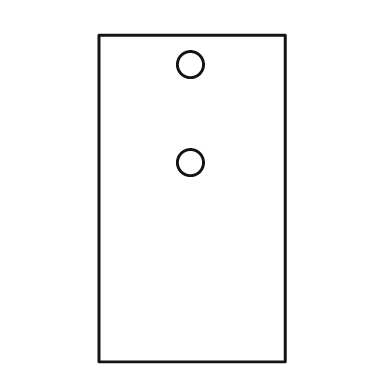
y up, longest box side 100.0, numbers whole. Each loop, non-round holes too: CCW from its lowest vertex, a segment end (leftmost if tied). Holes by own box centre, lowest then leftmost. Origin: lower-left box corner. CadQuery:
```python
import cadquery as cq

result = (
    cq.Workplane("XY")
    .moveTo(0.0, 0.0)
    .lineTo(57.0, 0.0)
    .lineTo(57.0, 100.0)
    .lineTo(0.0, 100.0)
    .close()
    .moveTo(28.0, 61.0)
    .circle(4.0)
    .moveTo(28.0, 91.0)
    .circle(4.0)
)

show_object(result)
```